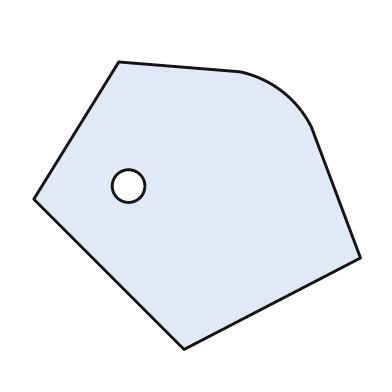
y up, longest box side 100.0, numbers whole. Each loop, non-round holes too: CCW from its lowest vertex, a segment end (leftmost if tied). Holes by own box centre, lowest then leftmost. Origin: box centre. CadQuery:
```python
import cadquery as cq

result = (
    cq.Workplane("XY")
    .moveTo(-4.0, -44.0)
    .lineTo(50.0, -16.0)
    .lineTo(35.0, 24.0)
    .threePointArc((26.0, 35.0), (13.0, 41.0))
    .lineTo(-24.0, 44.0)
    .lineTo(-50.0, 2.0)
    .close()
    .moveTo(-21.0, 6.0)
    .circle(5.0)
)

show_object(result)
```